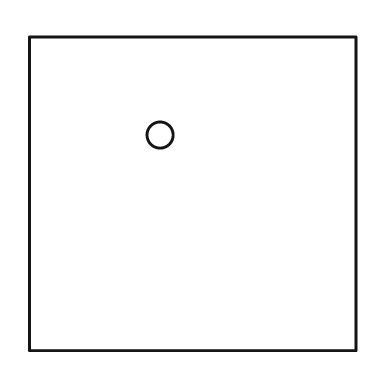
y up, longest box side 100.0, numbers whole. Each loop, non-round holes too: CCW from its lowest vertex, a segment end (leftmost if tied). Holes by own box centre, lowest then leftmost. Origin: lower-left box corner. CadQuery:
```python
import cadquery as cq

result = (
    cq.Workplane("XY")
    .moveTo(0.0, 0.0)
    .lineTo(100.0, 0.0)
    .lineTo(100.0, 96.0)
    .lineTo(0.0, 96.0)
    .close()
    .moveTo(40.0, 66.0)
    .circle(4.0)
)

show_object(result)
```